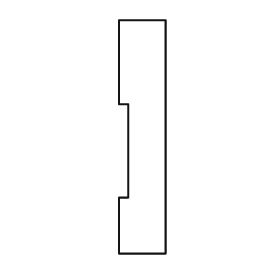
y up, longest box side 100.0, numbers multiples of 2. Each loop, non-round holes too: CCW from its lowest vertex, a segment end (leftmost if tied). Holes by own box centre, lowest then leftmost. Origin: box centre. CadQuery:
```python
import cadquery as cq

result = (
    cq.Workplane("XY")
    .moveTo(-10.0, -50.0)
    .lineTo(10.0, -50.0)
    .lineTo(10.0, 50.0)
    .lineTo(-10.0, 50.0)
    .lineTo(-10.0, 14.0)
    .lineTo(-6.0, 14.0)
    .lineTo(-6.0, -26.0)
    .lineTo(-10.0, -26.0)
    .close()
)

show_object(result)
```